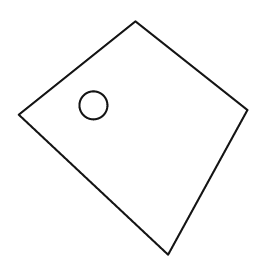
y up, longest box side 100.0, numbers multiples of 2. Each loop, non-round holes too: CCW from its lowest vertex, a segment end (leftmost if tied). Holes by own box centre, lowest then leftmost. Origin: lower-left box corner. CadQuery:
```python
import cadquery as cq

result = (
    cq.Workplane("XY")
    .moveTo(64.0, 0.0)
    .lineTo(98.0, 62.0)
    .lineTo(50.0, 100.0)
    .lineTo(0.0, 60.0)
    .close()
    .moveTo(32.0, 64.0)
    .circle(6.0)
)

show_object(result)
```